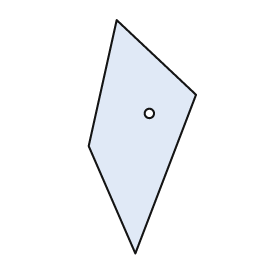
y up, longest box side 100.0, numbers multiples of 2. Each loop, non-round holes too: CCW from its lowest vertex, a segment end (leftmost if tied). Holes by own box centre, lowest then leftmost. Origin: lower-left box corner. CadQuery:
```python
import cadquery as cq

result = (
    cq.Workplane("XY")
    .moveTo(20.0, 0.0)
    .lineTo(46.0, 68.0)
    .lineTo(12.0, 100.0)
    .lineTo(0.0, 46.0)
    .close()
    .moveTo(26.0, 60.0)
    .circle(2.0)
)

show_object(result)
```